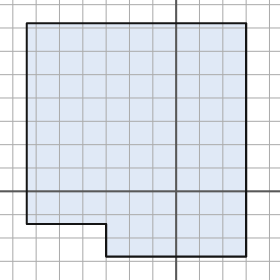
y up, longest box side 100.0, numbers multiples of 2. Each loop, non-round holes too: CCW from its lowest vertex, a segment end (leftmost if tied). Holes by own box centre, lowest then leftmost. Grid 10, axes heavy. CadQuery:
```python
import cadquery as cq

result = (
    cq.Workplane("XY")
    .moveTo(-30.0, -28.0)
    .lineTo(30.0, -28.0)
    .lineTo(30.0, 72.0)
    .lineTo(-64.0, 72.0)
    .lineTo(-64.0, -14.0)
    .lineTo(-30.0, -14.0)
    .close()
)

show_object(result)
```